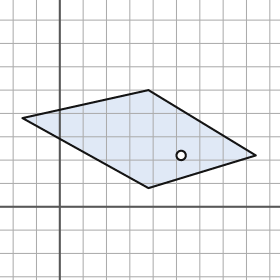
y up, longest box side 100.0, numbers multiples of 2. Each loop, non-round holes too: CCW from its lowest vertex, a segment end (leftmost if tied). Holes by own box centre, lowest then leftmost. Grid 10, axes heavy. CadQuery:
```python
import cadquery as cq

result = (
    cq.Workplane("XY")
    .moveTo(38.0, 8.0)
    .lineTo(84.0, 22.0)
    .lineTo(38.0, 50.0)
    .lineTo(-16.0, 38.0)
    .close()
    .moveTo(52.0, 22.0)
    .circle(2.0)
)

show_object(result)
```